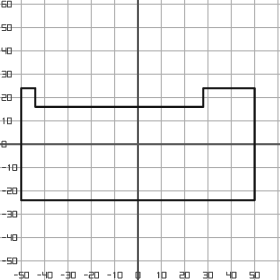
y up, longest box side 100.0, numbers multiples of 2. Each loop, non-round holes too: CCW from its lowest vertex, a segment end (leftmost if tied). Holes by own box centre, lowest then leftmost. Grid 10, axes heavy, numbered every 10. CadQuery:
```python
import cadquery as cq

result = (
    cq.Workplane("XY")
    .moveTo(-50.0, -24.0)
    .lineTo(50.0, -24.0)
    .lineTo(50.0, 24.0)
    .lineTo(28.0, 24.0)
    .lineTo(28.0, 16.0)
    .lineTo(-44.0, 16.0)
    .lineTo(-44.0, 24.0)
    .lineTo(-50.0, 24.0)
    .close()
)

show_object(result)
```